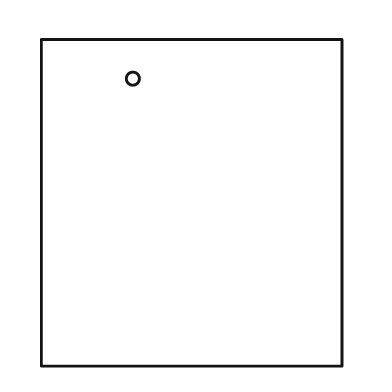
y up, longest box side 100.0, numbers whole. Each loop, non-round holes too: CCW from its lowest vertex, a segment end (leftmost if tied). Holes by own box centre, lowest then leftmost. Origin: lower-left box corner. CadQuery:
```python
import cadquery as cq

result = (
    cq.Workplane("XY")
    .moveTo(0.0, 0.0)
    .lineTo(92.0, 0.0)
    .lineTo(92.0, 100.0)
    .lineTo(0.0, 100.0)
    .close()
    .moveTo(28.0, 88.0)
    .circle(2.0)
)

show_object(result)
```